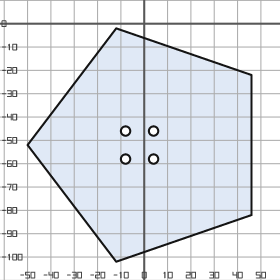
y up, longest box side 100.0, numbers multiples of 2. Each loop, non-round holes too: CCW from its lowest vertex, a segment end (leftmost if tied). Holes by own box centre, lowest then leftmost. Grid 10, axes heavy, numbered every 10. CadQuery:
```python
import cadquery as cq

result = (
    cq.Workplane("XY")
    .moveTo(-12.0, -102.0)
    .lineTo(46.0, -82.0)
    .lineTo(46.0, -22.0)
    .lineTo(-12.0, -2.0)
    .lineTo(-50.0, -52.0)
    .close()
    .moveTo(-8.0, -58.0)
    .circle(2.0)
    .moveTo(4.0, -58.0)
    .circle(2.0)
    .moveTo(-8.0, -46.0)
    .circle(2.0)
    .moveTo(4.0, -46.0)
    .circle(2.0)
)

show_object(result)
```